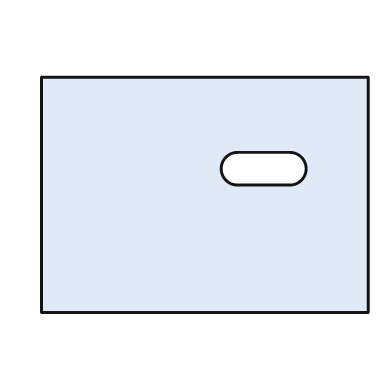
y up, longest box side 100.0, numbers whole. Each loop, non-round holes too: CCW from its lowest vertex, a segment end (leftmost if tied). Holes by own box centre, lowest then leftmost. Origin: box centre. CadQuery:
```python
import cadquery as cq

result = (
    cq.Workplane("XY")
    .moveTo(-50.0, -36.0)
    .lineTo(50.0, -36.0)
    .lineTo(50.0, 36.0)
    .lineTo(-50.0, 36.0)
    .close()
    .moveTo(10.0, 3.0)
    .lineTo(26.0, 3.0)
    .threePointArc((31.0, 8.0), (26.0, 13.0))
    .lineTo(10.0, 13.0)
    .threePointArc((5.0, 8.0), (10.0, 3.0))
    .close()
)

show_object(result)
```